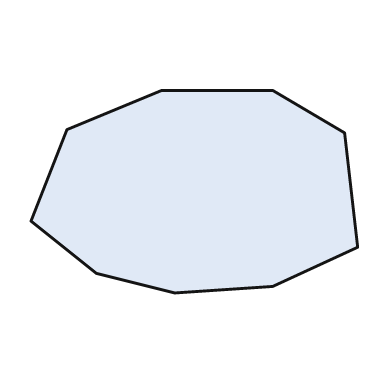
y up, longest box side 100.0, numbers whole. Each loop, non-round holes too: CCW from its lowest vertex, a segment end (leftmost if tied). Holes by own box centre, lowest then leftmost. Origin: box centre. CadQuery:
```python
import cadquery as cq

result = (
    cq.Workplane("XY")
    .moveTo(-6.0, -31.0)
    .lineTo(24.0, -29.0)
    .lineTo(50.0, -17.0)
    .lineTo(46.0, 18.0)
    .lineTo(24.0, 31.0)
    .lineTo(-10.0, 31.0)
    .lineTo(-39.0, 19.0)
    .lineTo(-50.0, -9.0)
    .lineTo(-30.0, -25.0)
    .close()
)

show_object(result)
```